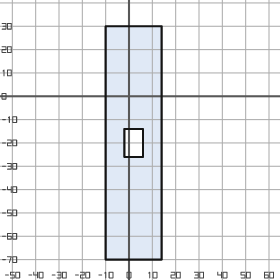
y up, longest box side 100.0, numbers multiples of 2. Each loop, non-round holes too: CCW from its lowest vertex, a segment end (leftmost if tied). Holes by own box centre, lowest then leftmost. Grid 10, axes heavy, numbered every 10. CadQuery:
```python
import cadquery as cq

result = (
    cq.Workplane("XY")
    .moveTo(-10.0, -70.0)
    .lineTo(14.0, -70.0)
    .lineTo(14.0, 30.0)
    .lineTo(-10.0, 30.0)
    .close()
    .moveTo(-2.0, -26.0)
    .lineTo(6.0, -26.0)
    .lineTo(6.0, -14.0)
    .lineTo(-2.0, -14.0)
    .close()
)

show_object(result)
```